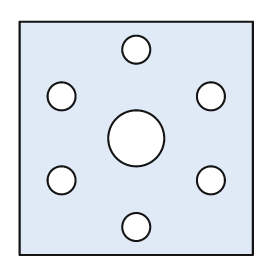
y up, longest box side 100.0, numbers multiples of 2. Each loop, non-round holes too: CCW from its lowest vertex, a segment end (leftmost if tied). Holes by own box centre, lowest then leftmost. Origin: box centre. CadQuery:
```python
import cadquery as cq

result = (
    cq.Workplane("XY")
    .moveTo(-50.0, -50.0)
    .lineTo(50.0, -50.0)
    .lineTo(50.0, 50.0)
    .lineTo(-50.0, 50.0)
    .close()
    .moveTo(0.0, -38.0)
    .circle(6.0)
    .moveTo(-32.0, -18.0)
    .circle(6.0)
    .moveTo(32.0, -18.0)
    .circle(6.0)
    .moveTo(0.0, 0.0)
    .circle(12.0)
    .moveTo(-32.0, 18.0)
    .circle(6.0)
    .moveTo(32.0, 18.0)
    .circle(6.0)
    .moveTo(0.0, 38.0)
    .circle(6.0)
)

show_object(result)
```